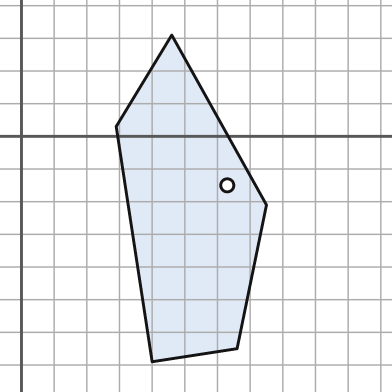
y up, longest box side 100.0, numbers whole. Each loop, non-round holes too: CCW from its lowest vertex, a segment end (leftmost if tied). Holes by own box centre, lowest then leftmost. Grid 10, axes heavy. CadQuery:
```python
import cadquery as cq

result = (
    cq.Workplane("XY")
    .moveTo(40.0, -69.0)
    .lineTo(66.0, -65.0)
    .lineTo(75.0, -21.0)
    .lineTo(46.0, 31.0)
    .lineTo(29.0, 3.0)
    .close()
    .moveTo(63.0, -15.0)
    .circle(2.0)
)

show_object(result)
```